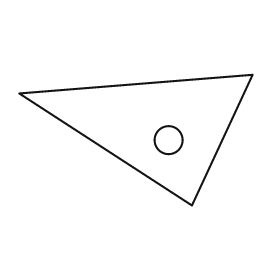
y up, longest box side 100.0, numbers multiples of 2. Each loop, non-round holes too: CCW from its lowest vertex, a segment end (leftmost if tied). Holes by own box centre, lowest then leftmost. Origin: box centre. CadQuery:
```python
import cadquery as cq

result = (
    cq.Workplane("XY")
    .moveTo(24.0, -28.0)
    .lineTo(50.0, 28.0)
    .lineTo(-50.0, 20.0)
    .close()
    .moveTo(14.0, 0.0)
    .circle(6.0)
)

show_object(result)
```